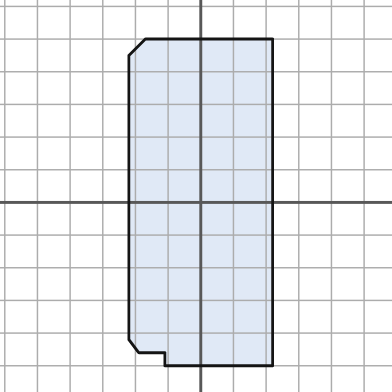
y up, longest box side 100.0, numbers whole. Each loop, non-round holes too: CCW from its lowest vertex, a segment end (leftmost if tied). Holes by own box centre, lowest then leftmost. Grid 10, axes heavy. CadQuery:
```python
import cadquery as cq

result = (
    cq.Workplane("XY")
    .moveTo(-11.0, -50.0)
    .lineTo(22.0, -50.0)
    .lineTo(22.0, 50.0)
    .lineTo(-17.0, 50.0)
    .lineTo(-22.0, 45.0)
    .lineTo(-22.0, -42.0)
    .lineTo(-19.0, -46.0)
    .lineTo(-11.0, -46.0)
    .close()
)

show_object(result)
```